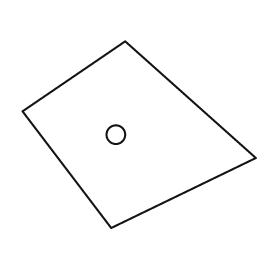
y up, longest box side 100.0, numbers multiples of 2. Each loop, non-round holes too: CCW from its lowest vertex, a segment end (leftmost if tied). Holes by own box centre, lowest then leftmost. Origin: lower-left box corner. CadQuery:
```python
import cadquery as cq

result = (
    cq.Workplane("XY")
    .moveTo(38.0, 0.0)
    .lineTo(100.0, 30.0)
    .lineTo(44.0, 80.0)
    .lineTo(0.0, 50.0)
    .close()
    .moveTo(40.0, 40.0)
    .circle(4.0)
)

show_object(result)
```